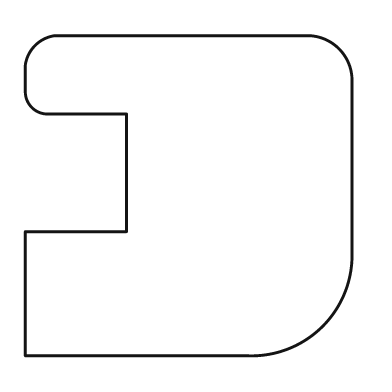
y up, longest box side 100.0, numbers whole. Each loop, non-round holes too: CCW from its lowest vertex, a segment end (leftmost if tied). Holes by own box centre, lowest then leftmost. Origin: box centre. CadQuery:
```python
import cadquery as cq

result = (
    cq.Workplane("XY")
    .moveTo(-50.0, -49.0)
    .lineTo(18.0, -49.0)
    .threePointArc((41.0, -40.0), (50.0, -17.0))
    .lineTo(50.0, 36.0)
    .threePointArc((46.0, 45.0), (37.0, 49.0))
    .lineTo(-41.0, 49.0)
    .threePointArc((-47.0, 46.0), (-50.0, 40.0))
    .lineTo(-50.0, 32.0)
    .threePointArc((-48.0, 27.0), (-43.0, 25.0))
    .lineTo(-19.0, 25.0)
    .lineTo(-19.0, -11.0)
    .lineTo(-50.0, -11.0)
    .close()
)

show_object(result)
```